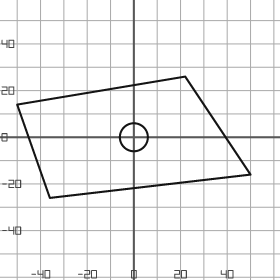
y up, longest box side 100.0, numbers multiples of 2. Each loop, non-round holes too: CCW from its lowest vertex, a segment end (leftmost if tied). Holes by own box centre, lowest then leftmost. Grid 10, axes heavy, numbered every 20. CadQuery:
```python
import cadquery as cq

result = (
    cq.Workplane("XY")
    .moveTo(-36.0, -26.0)
    .lineTo(50.0, -16.0)
    .lineTo(22.0, 26.0)
    .lineTo(-50.0, 14.0)
    .close()
    .moveTo(0.0, 0.0)
    .circle(6.0)
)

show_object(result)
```